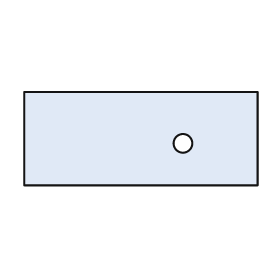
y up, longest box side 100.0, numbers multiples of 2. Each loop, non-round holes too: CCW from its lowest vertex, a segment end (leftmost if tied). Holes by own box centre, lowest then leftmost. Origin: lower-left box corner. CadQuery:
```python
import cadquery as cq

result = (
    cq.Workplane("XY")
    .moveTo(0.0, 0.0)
    .lineTo(100.0, 0.0)
    .lineTo(100.0, 40.0)
    .lineTo(0.0, 40.0)
    .close()
    .moveTo(68.0, 18.0)
    .circle(4.0)
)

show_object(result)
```